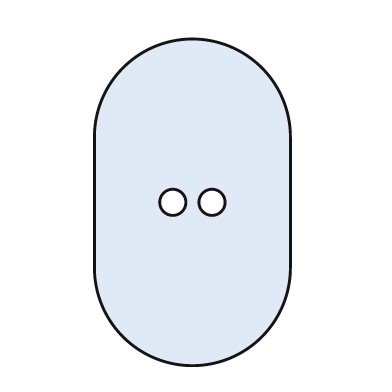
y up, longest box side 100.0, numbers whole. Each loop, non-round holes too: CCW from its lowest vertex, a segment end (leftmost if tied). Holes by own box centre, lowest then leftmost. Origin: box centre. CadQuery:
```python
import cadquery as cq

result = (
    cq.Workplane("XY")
    .moveTo(-30.0, -20.0)
    .threePointArc((0.0, -50.0), (30.0, -20.0))
    .lineTo(30.0, 20.0)
    .threePointArc((0.0, 50.0), (-30.0, 20.0))
    .close()
    .moveTo(-6.0, 0.0)
    .circle(4.0)
    .moveTo(6.0, 0.0)
    .circle(4.0)
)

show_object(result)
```